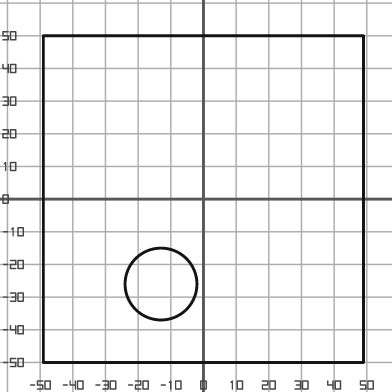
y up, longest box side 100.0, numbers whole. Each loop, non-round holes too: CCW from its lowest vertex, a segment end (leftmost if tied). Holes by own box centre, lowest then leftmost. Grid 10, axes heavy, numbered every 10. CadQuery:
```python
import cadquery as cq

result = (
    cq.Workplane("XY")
    .moveTo(-49.0, -50.0)
    .lineTo(49.0, -50.0)
    .lineTo(49.0, 50.0)
    .lineTo(-49.0, 50.0)
    .close()
    .moveTo(-13.0, -26.0)
    .circle(11.0)
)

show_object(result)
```